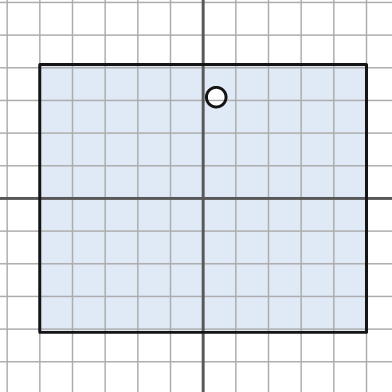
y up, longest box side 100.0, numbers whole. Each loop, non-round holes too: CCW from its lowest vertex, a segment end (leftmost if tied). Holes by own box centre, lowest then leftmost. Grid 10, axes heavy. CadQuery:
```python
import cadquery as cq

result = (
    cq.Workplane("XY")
    .moveTo(-50.0, -41.0)
    .lineTo(50.0, -41.0)
    .lineTo(50.0, 41.0)
    .lineTo(-50.0, 41.0)
    .close()
    .moveTo(4.0, 31.0)
    .circle(3.0)
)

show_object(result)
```